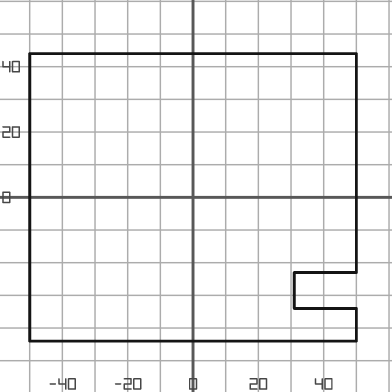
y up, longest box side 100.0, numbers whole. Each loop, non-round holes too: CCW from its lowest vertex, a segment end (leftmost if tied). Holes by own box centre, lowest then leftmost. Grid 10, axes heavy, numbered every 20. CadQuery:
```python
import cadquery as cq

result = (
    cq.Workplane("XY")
    .moveTo(-50.0, -44.0)
    .lineTo(50.0, -44.0)
    .lineTo(50.0, -34.0)
    .lineTo(31.0, -34.0)
    .lineTo(31.0, -23.0)
    .lineTo(50.0, -23.0)
    .lineTo(50.0, 44.0)
    .lineTo(-50.0, 44.0)
    .close()
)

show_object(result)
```